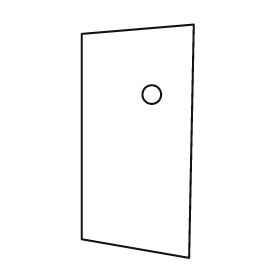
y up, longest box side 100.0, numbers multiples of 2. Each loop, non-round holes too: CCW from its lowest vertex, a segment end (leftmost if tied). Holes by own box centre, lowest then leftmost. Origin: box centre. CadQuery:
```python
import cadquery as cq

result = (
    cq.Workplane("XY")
    .moveTo(22.0, -50.0)
    .lineTo(24.0, 50.0)
    .lineTo(-24.0, 46.0)
    .lineTo(-24.0, -42.0)
    .close()
    .moveTo(6.0, 20.0)
    .circle(4.0)
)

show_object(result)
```